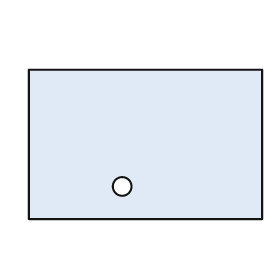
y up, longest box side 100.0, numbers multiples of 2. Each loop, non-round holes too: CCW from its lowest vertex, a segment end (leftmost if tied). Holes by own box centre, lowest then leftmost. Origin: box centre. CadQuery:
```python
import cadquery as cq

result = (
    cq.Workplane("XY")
    .moveTo(-50.0, -32.0)
    .lineTo(50.0, -32.0)
    .lineTo(50.0, 32.0)
    .lineTo(-50.0, 32.0)
    .close()
    .moveTo(-10.0, -18.0)
    .circle(4.0)
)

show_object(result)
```